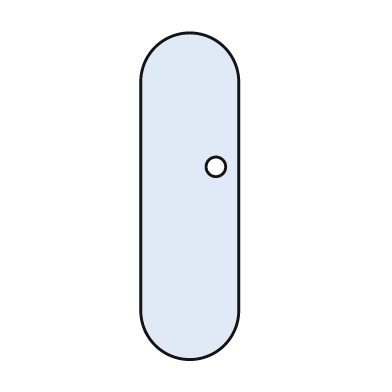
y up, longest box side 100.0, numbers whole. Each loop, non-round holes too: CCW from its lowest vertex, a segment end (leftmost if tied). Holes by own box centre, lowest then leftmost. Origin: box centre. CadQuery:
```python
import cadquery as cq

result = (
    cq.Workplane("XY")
    .moveTo(-15.0, -35.0)
    .threePointArc((0.0, -50.0), (15.0, -35.0))
    .lineTo(15.0, 35.0)
    .threePointArc((0.0, 50.0), (-15.0, 35.0))
    .close()
    .moveTo(8.0, 9.0)
    .circle(3.0)
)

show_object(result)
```